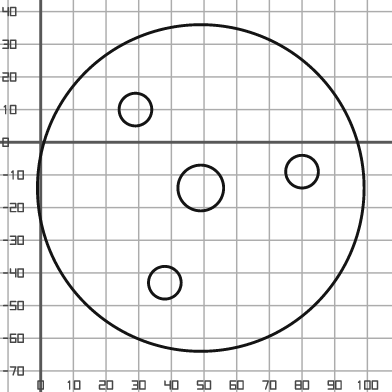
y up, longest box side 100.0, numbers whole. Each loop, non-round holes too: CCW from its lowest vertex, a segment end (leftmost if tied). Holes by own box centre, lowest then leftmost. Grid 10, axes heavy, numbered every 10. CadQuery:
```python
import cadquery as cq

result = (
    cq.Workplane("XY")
    .moveTo(49.0, -14.0)
    .circle(50.0)
    .moveTo(38.0, -43.0)
    .circle(5.0)
    .moveTo(49.0, -14.0)
    .circle(7.0)
    .moveTo(80.0, -9.0)
    .circle(5.0)
    .moveTo(29.0, 10.0)
    .circle(5.0)
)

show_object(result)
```